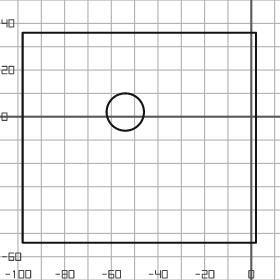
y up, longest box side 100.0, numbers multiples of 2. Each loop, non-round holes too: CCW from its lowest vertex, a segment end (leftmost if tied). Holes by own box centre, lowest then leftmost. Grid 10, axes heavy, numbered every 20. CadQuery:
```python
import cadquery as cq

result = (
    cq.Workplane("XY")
    .moveTo(-98.0, -54.0)
    .lineTo(2.0, -54.0)
    .lineTo(2.0, 36.0)
    .lineTo(-98.0, 36.0)
    .close()
    .moveTo(-54.0, 2.0)
    .circle(8.0)
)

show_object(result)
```